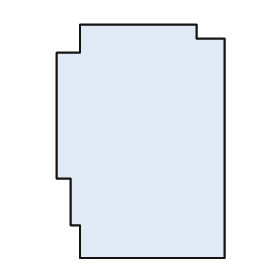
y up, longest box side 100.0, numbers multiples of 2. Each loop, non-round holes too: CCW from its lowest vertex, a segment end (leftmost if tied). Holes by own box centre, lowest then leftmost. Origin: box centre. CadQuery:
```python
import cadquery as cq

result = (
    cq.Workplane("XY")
    .moveTo(-26.0, -50.0)
    .lineTo(36.0, -50.0)
    .lineTo(36.0, 44.0)
    .lineTo(24.0, 44.0)
    .lineTo(24.0, 50.0)
    .lineTo(-26.0, 50.0)
    .lineTo(-26.0, 38.0)
    .lineTo(-36.0, 38.0)
    .lineTo(-36.0, -16.0)
    .lineTo(-30.0, -16.0)
    .lineTo(-30.0, -36.0)
    .lineTo(-26.0, -36.0)
    .close()
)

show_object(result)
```